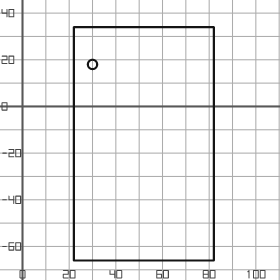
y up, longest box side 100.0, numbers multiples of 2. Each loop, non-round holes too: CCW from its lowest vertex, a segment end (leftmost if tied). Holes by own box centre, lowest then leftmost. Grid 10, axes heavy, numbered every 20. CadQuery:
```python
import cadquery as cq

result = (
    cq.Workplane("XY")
    .moveTo(22.0, -66.0)
    .lineTo(82.0, -66.0)
    .lineTo(82.0, 34.0)
    .lineTo(22.0, 34.0)
    .close()
    .moveTo(30.0, 18.0)
    .circle(2.0)
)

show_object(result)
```